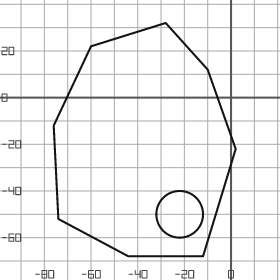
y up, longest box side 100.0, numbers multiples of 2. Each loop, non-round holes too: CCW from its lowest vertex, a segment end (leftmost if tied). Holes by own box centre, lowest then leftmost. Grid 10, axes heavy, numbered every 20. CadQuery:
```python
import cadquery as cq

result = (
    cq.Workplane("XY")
    .moveTo(-44.0, -68.0)
    .lineTo(-12.0, -68.0)
    .lineTo(2.0, -22.0)
    .lineTo(-10.0, 12.0)
    .lineTo(-28.0, 32.0)
    .lineTo(-60.0, 22.0)
    .lineTo(-76.0, -12.0)
    .lineTo(-74.0, -52.0)
    .close()
    .moveTo(-22.0, -50.0)
    .circle(10.0)
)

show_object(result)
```